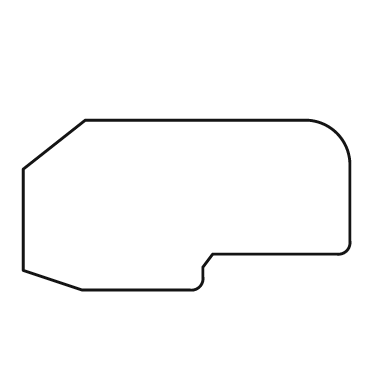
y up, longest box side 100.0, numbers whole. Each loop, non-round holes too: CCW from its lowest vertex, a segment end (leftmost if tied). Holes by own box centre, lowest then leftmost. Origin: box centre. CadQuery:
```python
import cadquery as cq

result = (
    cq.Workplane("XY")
    .moveTo(-32.0, -26.0)
    .lineTo(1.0, -26.0)
    .threePointArc((4.0, -25.0), (5.0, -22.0))
    .lineTo(5.0, -19.0)
    .lineTo(8.0, -15.0)
    .lineTo(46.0, -15.0)
    .threePointArc((49.0, -14.0), (50.0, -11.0))
    .lineTo(50.0, 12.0)
    .threePointArc((46.0, 22.0), (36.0, 26.0))
    .lineTo(-31.0, 26.0)
    .lineTo(-50.0, 11.0)
    .lineTo(-50.0, -20.0)
    .close()
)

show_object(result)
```